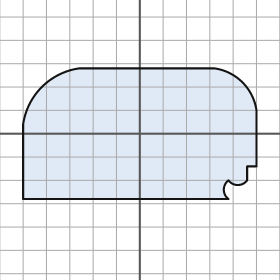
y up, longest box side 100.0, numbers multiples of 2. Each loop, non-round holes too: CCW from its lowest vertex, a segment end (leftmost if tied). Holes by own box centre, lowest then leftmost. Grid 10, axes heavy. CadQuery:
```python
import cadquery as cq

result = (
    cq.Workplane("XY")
    .moveTo(-50.0, -28.0)
    .lineTo(38.0, -28.0)
    .threePointArc((36.0, -24.0), (38.0, -20.0))
    .threePointArc((42.0, -22.0), (46.0, -20.0))
    .lineTo(46.0, -14.0)
    .lineTo(50.0, -14.0)
    .lineTo(50.0, 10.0)
    .threePointArc((44.0, 22.0), (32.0, 28.0))
    .lineTo(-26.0, 28.0)
    .threePointArc((-42.0, 20.0), (-50.0, 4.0))
    .close()
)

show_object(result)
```